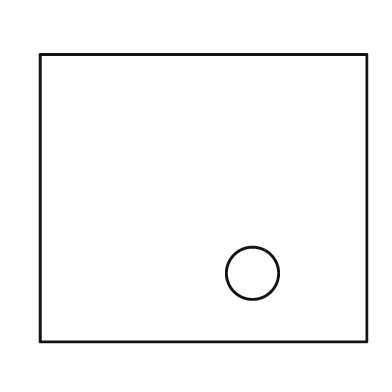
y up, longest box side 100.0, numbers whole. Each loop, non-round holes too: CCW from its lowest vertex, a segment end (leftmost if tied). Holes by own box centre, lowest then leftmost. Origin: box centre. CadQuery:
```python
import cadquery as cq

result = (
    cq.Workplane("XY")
    .moveTo(-50.0, -44.0)
    .lineTo(50.0, -44.0)
    .lineTo(50.0, 44.0)
    .lineTo(-50.0, 44.0)
    .close()
    .moveTo(15.0, -23.0)
    .circle(8.0)
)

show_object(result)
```